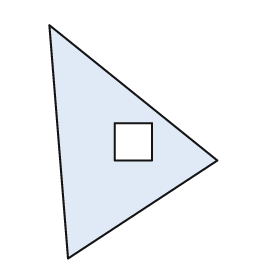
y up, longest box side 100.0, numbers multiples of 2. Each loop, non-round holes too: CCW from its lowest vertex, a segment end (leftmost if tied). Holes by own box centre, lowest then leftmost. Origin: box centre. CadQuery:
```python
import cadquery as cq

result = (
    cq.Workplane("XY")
    .moveTo(-28.0, -50.0)
    .lineTo(36.0, -8.0)
    .lineTo(-36.0, 50.0)
    .close()
    .moveTo(-8.0, -8.0)
    .lineTo(8.0, -8.0)
    .lineTo(8.0, 8.0)
    .lineTo(-8.0, 8.0)
    .close()
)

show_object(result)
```